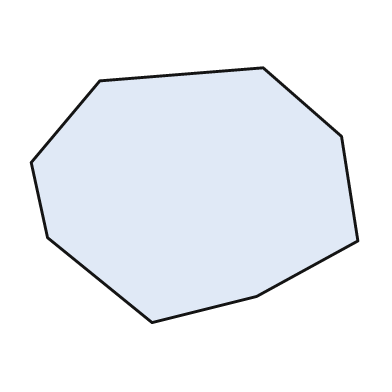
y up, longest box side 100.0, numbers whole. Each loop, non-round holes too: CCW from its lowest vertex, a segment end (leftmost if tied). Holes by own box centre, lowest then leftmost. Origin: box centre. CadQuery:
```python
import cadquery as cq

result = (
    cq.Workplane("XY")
    .moveTo(-13.0, -39.0)
    .lineTo(19.0, -31.0)
    .lineTo(50.0, -14.0)
    .lineTo(45.0, 18.0)
    .lineTo(21.0, 39.0)
    .lineTo(-29.0, 35.0)
    .lineTo(-50.0, 10.0)
    .lineTo(-45.0, -13.0)
    .close()
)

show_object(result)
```